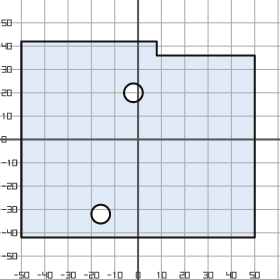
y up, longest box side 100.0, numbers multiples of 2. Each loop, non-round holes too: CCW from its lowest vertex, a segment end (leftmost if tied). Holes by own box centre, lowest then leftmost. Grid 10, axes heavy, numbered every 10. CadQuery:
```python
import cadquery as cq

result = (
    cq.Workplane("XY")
    .moveTo(-50.0, -42.0)
    .lineTo(50.0, -42.0)
    .lineTo(50.0, 36.0)
    .lineTo(8.0, 36.0)
    .lineTo(8.0, 42.0)
    .lineTo(-50.0, 42.0)
    .close()
    .moveTo(-16.0, -32.0)
    .circle(4.0)
    .moveTo(-2.0, 20.0)
    .circle(4.0)
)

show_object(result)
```